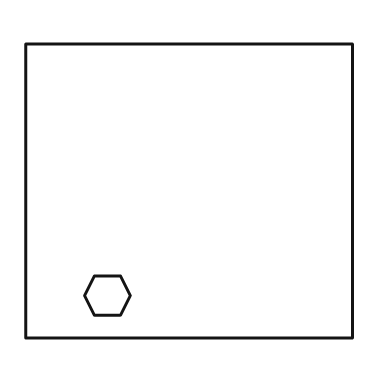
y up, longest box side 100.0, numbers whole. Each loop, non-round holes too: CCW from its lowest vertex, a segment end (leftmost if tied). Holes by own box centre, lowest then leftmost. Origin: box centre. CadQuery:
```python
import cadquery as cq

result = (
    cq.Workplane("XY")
    .moveTo(-50.0, -45.0)
    .lineTo(50.0, -45.0)
    .lineTo(50.0, 45.0)
    .lineTo(-50.0, 45.0)
    .close()
    .moveTo(-29.0, -38.0)
    .lineTo(-21.0, -38.0)
    .lineTo(-18.0, -32.0)
    .lineTo(-21.0, -26.0)
    .lineTo(-29.0, -26.0)
    .lineTo(-32.0, -32.0)
    .close()
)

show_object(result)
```